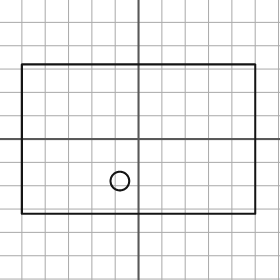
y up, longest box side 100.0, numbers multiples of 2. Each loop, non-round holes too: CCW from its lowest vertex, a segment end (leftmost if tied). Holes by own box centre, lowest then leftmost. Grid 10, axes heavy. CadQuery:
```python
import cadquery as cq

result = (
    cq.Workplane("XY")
    .moveTo(-50.0, -32.0)
    .lineTo(50.0, -32.0)
    .lineTo(50.0, 32.0)
    .lineTo(-50.0, 32.0)
    .close()
    .moveTo(-8.0, -18.0)
    .circle(4.0)
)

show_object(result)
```